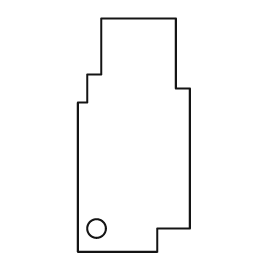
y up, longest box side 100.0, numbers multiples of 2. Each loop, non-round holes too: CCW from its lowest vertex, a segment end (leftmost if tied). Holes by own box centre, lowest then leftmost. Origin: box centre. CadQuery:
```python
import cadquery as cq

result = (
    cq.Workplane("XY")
    .moveTo(-24.0, -50.0)
    .lineTo(10.0, -50.0)
    .lineTo(10.0, -40.0)
    .lineTo(24.0, -40.0)
    .lineTo(24.0, 20.0)
    .lineTo(18.0, 20.0)
    .lineTo(18.0, 50.0)
    .lineTo(-14.0, 50.0)
    .lineTo(-14.0, 26.0)
    .lineTo(-20.0, 26.0)
    .lineTo(-20.0, 14.0)
    .lineTo(-24.0, 14.0)
    .close()
    .moveTo(-16.0, -40.0)
    .circle(4.0)
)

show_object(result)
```